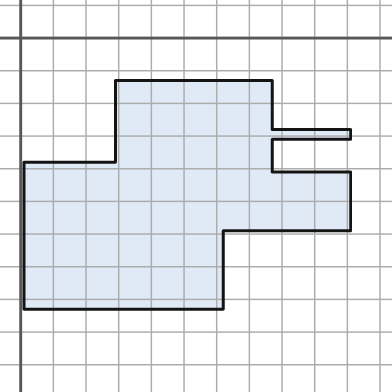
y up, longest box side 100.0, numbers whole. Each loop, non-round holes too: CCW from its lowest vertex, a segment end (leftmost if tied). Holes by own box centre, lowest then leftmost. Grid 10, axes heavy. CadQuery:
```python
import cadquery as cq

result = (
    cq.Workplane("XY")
    .moveTo(1.0, -83.0)
    .lineTo(62.0, -83.0)
    .lineTo(62.0, -59.0)
    .lineTo(101.0, -59.0)
    .lineTo(101.0, -41.0)
    .lineTo(77.0, -41.0)
    .lineTo(77.0, -31.0)
    .lineTo(101.0, -31.0)
    .lineTo(101.0, -28.0)
    .lineTo(77.0, -28.0)
    .lineTo(77.0, -13.0)
    .lineTo(29.0, -13.0)
    .lineTo(29.0, -38.0)
    .lineTo(1.0, -38.0)
    .close()
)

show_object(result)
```